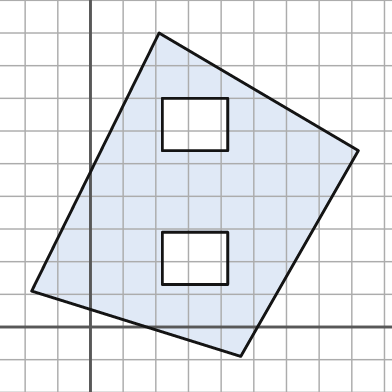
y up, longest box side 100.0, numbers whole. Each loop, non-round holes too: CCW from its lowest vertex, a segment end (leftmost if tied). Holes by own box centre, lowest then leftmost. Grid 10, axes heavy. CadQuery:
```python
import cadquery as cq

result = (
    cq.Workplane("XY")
    .moveTo(46.0, -9.0)
    .lineTo(82.0, 54.0)
    .lineTo(21.0, 90.0)
    .lineTo(-18.0, 11.0)
    .close()
    .moveTo(22.0, 13.0)
    .lineTo(42.0, 13.0)
    .lineTo(42.0, 29.0)
    .lineTo(22.0, 29.0)
    .close()
    .moveTo(22.0, 54.0)
    .lineTo(42.0, 54.0)
    .lineTo(42.0, 70.0)
    .lineTo(22.0, 70.0)
    .close()
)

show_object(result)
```